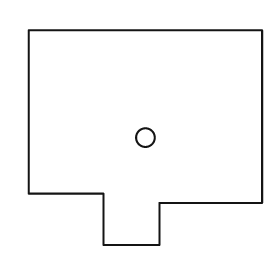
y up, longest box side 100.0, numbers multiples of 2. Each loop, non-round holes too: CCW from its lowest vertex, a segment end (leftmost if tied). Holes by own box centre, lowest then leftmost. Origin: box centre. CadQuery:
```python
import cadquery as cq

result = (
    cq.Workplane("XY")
    .moveTo(-18.0, -46.0)
    .lineTo(6.0, -46.0)
    .lineTo(6.0, -28.0)
    .lineTo(50.0, -28.0)
    .lineTo(50.0, 46.0)
    .lineTo(-50.0, 46.0)
    .lineTo(-50.0, -24.0)
    .lineTo(-18.0, -24.0)
    .close()
    .moveTo(0.0, 0.0)
    .circle(4.0)
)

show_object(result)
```